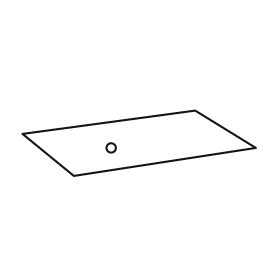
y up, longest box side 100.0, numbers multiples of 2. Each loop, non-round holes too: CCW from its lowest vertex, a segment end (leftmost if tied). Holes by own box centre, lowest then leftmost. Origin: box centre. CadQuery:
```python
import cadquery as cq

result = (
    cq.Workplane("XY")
    .moveTo(-28.0, -14.0)
    .lineTo(50.0, -2.0)
    .lineTo(24.0, 14.0)
    .lineTo(-50.0, 4.0)
    .close()
    .moveTo(-12.0, -2.0)
    .circle(2.0)
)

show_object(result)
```